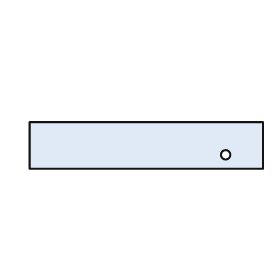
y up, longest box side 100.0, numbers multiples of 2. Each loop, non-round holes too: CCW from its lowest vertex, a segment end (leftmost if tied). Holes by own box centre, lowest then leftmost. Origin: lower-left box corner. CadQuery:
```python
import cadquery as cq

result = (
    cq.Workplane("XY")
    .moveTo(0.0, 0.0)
    .lineTo(100.0, 0.0)
    .lineTo(100.0, 20.0)
    .lineTo(0.0, 20.0)
    .close()
    .moveTo(84.0, 6.0)
    .circle(2.0)
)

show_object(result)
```